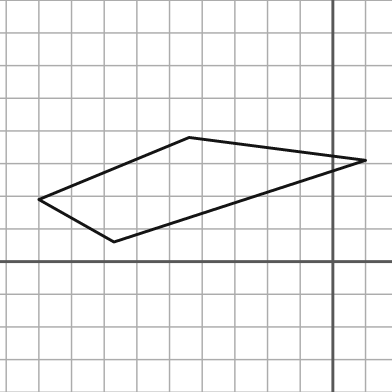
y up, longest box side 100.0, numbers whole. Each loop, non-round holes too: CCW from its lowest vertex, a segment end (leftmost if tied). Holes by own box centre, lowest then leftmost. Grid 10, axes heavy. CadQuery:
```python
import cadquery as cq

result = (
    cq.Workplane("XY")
    .moveTo(-67.0, 6.0)
    .lineTo(10.0, 31.0)
    .lineTo(-44.0, 38.0)
    .lineTo(-90.0, 19.0)
    .close()
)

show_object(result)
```